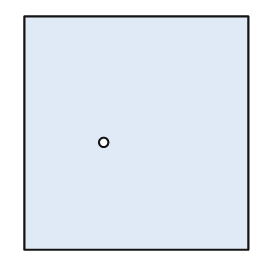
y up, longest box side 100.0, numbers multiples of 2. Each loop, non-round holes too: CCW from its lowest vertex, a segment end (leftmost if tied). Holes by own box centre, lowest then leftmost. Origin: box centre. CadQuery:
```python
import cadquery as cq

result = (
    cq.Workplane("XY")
    .moveTo(-48.0, -50.0)
    .lineTo(48.0, -50.0)
    .lineTo(48.0, 50.0)
    .lineTo(-48.0, 50.0)
    .close()
    .moveTo(-14.0, -4.0)
    .circle(2.0)
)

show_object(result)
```